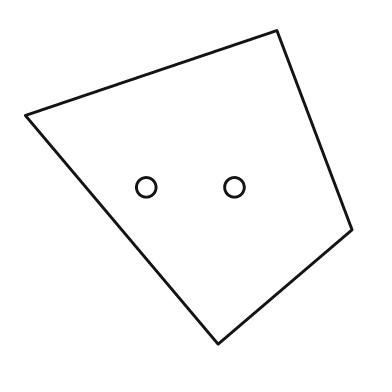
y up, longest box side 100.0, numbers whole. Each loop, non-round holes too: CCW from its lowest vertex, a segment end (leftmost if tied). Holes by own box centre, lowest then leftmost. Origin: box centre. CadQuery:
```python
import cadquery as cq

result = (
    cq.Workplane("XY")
    .moveTo(9.0, -48.0)
    .lineTo(50.0, -13.0)
    .lineTo(27.0, 48.0)
    .lineTo(-50.0, 22.0)
    .close()
    .moveTo(-13.0, 0.0)
    .circle(3.0)
    .moveTo(14.0, 0.0)
    .circle(3.0)
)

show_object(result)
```